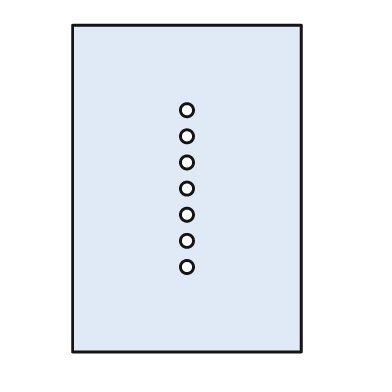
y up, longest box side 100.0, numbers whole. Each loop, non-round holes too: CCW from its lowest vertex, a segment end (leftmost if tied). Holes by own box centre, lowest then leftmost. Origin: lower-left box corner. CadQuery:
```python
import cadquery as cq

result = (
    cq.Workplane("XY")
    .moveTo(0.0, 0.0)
    .lineTo(70.0, 0.0)
    .lineTo(70.0, 100.0)
    .lineTo(0.0, 100.0)
    .close()
    .moveTo(35.0, 26.0)
    .circle(2.0)
    .moveTo(35.0, 34.0)
    .circle(2.0)
    .moveTo(35.0, 42.0)
    .circle(2.0)
    .moveTo(35.0, 50.0)
    .circle(2.0)
    .moveTo(35.0, 58.0)
    .circle(2.0)
    .moveTo(35.0, 66.0)
    .circle(2.0)
    .moveTo(35.0, 74.0)
    .circle(2.0)
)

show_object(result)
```